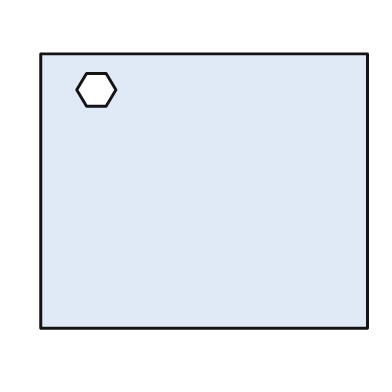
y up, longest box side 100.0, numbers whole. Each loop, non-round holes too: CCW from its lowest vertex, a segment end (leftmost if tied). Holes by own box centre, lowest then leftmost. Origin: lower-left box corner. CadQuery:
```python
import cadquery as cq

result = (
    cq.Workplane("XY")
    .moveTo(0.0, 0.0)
    .lineTo(100.0, 0.0)
    .lineTo(100.0, 84.0)
    .lineTo(0.0, 84.0)
    .close()
    .moveTo(14.0, 68.0)
    .lineTo(20.0, 68.0)
    .lineTo(23.0, 73.0)
    .lineTo(20.0, 78.0)
    .lineTo(14.0, 78.0)
    .lineTo(11.0, 73.0)
    .close()
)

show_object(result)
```